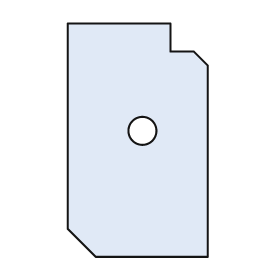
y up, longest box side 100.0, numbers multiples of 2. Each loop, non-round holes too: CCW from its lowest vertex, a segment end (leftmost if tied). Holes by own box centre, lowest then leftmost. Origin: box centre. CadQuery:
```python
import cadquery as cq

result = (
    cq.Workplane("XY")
    .moveTo(-18.0, -50.0)
    .lineTo(30.0, -50.0)
    .lineTo(30.0, 32.0)
    .lineTo(24.0, 38.0)
    .lineTo(14.0, 38.0)
    .lineTo(14.0, 50.0)
    .lineTo(-30.0, 50.0)
    .lineTo(-30.0, -38.0)
    .close()
    .moveTo(2.0, 4.0)
    .circle(6.0)
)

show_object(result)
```